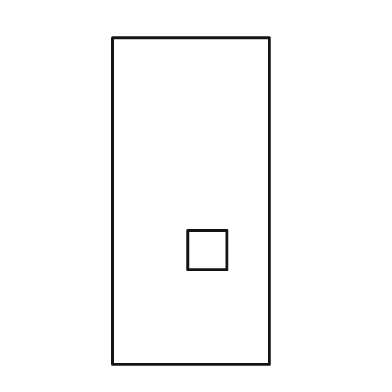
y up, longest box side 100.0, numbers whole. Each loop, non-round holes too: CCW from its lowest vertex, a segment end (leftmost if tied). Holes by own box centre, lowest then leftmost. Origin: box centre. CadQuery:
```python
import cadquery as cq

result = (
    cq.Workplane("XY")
    .moveTo(-24.0, -50.0)
    .lineTo(24.0, -50.0)
    .lineTo(24.0, 50.0)
    .lineTo(-24.0, 50.0)
    .close()
    .moveTo(-1.0, -21.0)
    .lineTo(11.0, -21.0)
    .lineTo(11.0, -9.0)
    .lineTo(-1.0, -9.0)
    .close()
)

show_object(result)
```